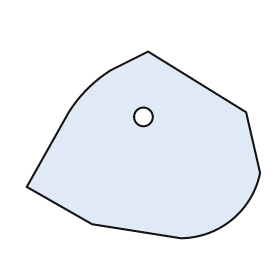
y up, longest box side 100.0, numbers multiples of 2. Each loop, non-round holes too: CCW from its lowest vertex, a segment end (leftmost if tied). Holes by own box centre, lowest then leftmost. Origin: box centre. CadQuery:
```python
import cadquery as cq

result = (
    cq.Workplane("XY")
    .moveTo(16.0, -40.0)
    .threePointArc((38.0, -32.0), (50.0, -12.0))
    .lineTo(44.0, 14.0)
    .lineTo(2.0, 40.0)
    .lineTo(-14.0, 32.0)
    .threePointArc((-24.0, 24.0), (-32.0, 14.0))
    .lineTo(-50.0, -18.0)
    .lineTo(-22.0, -34.0)
    .close()
    .moveTo(0.0, 12.0)
    .circle(4.0)
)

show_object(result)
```